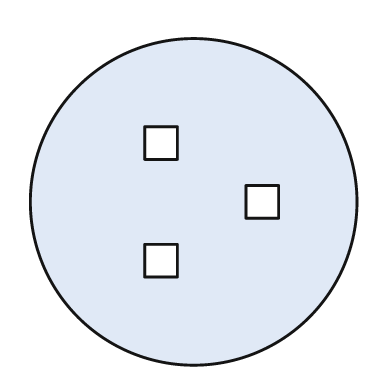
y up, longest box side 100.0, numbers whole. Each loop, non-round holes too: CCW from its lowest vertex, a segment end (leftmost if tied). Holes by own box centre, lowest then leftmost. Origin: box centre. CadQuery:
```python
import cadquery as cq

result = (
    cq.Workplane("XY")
    .moveTo(0.0, 0.0)
    .circle(50.0)
    .moveTo(-15.0, -23.0)
    .lineTo(-5.0, -23.0)
    .lineTo(-5.0, -13.0)
    .lineTo(-15.0, -13.0)
    .close()
    .moveTo(16.0, -5.0)
    .lineTo(26.0, -5.0)
    .lineTo(26.0, 5.0)
    .lineTo(16.0, 5.0)
    .close()
    .moveTo(-15.0, 13.0)
    .lineTo(-5.0, 13.0)
    .lineTo(-5.0, 23.0)
    .lineTo(-15.0, 23.0)
    .close()
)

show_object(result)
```